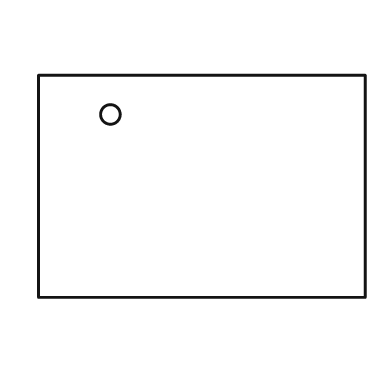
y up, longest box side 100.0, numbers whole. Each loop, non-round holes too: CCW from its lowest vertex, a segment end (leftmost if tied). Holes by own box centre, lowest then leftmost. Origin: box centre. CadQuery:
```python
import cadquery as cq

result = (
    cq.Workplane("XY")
    .moveTo(-50.0, -34.0)
    .lineTo(50.0, -34.0)
    .lineTo(50.0, 34.0)
    .lineTo(-50.0, 34.0)
    .close()
    .moveTo(-28.0, 22.0)
    .circle(3.0)
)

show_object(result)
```